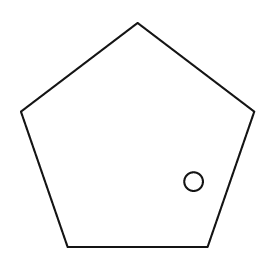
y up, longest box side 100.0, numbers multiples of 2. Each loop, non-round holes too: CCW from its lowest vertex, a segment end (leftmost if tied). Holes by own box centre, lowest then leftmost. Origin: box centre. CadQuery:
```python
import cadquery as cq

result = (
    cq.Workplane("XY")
    .moveTo(-30.0, -48.0)
    .lineTo(30.0, -48.0)
    .lineTo(50.0, 10.0)
    .lineTo(0.0, 48.0)
    .lineTo(-50.0, 10.0)
    .close()
    .moveTo(24.0, -20.0)
    .circle(4.0)
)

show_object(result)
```